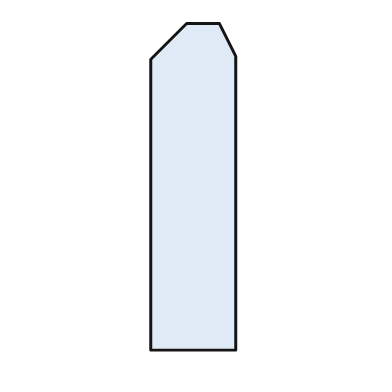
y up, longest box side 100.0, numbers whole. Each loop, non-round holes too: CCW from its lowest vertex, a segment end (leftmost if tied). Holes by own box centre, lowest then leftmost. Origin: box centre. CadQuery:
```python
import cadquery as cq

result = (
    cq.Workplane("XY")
    .moveTo(-13.0, -50.0)
    .lineTo(13.0, -50.0)
    .lineTo(13.0, 40.0)
    .lineTo(8.0, 50.0)
    .lineTo(-2.0, 50.0)
    .lineTo(-13.0, 39.0)
    .close()
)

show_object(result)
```